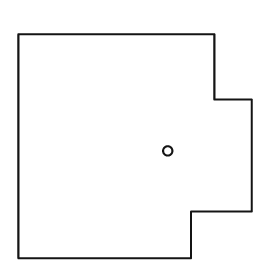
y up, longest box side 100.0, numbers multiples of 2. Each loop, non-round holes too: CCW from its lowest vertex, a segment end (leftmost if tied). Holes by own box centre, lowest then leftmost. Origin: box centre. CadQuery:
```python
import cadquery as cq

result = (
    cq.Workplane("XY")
    .moveTo(-50.0, -48.0)
    .lineTo(24.0, -48.0)
    .lineTo(24.0, -28.0)
    .lineTo(50.0, -28.0)
    .lineTo(50.0, 20.0)
    .lineTo(34.0, 20.0)
    .lineTo(34.0, 48.0)
    .lineTo(-50.0, 48.0)
    .close()
    .moveTo(14.0, -2.0)
    .circle(2.0)
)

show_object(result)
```